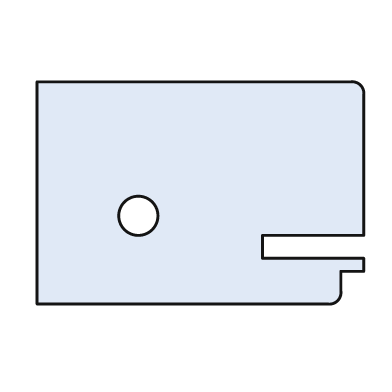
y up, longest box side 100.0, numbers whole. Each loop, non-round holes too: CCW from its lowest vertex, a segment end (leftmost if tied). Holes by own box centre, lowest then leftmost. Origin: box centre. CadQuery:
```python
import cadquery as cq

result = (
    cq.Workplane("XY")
    .moveTo(-50.0, -34.0)
    .lineTo(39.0, -34.0)
    .threePointArc((42.0, -33.0), (43.0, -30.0))
    .lineTo(43.0, -24.0)
    .lineTo(50.0, -24.0)
    .lineTo(50.0, -20.0)
    .lineTo(19.0, -20.0)
    .lineTo(19.0, -13.0)
    .lineTo(50.0, -13.0)
    .lineTo(50.0, 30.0)
    .threePointArc((49.0, 33.0), (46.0, 34.0))
    .lineTo(-50.0, 34.0)
    .close()
    .moveTo(-19.0, -7.0)
    .circle(6.0)
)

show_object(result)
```